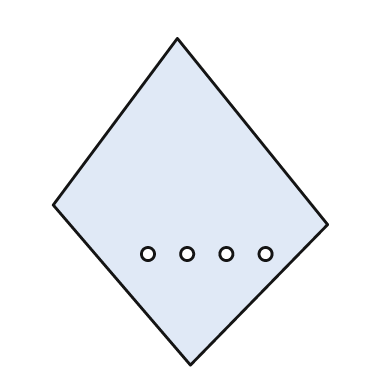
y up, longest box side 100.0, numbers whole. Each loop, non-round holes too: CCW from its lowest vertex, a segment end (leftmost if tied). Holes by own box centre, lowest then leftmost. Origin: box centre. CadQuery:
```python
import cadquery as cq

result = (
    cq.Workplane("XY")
    .moveTo(0.0, -50.0)
    .lineTo(42.0, -7.0)
    .lineTo(-4.0, 50.0)
    .lineTo(-42.0, -1.0)
    .close()
    .moveTo(-13.0, -16.0)
    .circle(2.0)
    .moveTo(-1.0, -16.0)
    .circle(2.0)
    .moveTo(11.0, -16.0)
    .circle(2.0)
    .moveTo(23.0, -16.0)
    .circle(2.0)
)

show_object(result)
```